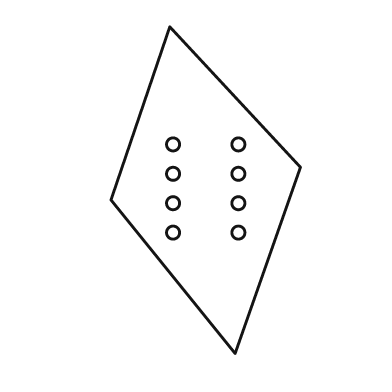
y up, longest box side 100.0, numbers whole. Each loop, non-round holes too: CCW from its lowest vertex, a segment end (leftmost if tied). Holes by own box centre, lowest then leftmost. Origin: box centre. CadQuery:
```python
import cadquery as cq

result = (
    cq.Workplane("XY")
    .moveTo(9.0, -50.0)
    .lineTo(29.0, 7.0)
    .lineTo(-11.0, 50.0)
    .lineTo(-29.0, -3.0)
    .close()
    .moveTo(-10.0, -13.0)
    .circle(2.0)
    .moveTo(10.0, -13.0)
    .circle(2.0)
    .moveTo(-10.0, -4.0)
    .circle(2.0)
    .moveTo(10.0, -4.0)
    .circle(2.0)
    .moveTo(-10.0, 5.0)
    .circle(2.0)
    .moveTo(10.0, 5.0)
    .circle(2.0)
    .moveTo(-10.0, 14.0)
    .circle(2.0)
    .moveTo(10.0, 14.0)
    .circle(2.0)
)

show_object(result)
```